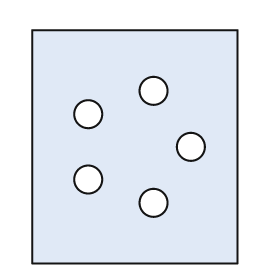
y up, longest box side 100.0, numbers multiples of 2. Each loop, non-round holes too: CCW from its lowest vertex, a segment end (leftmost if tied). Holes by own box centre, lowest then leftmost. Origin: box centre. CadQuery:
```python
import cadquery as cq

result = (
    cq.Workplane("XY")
    .moveTo(-44.0, -50.0)
    .lineTo(44.0, -50.0)
    .lineTo(44.0, 50.0)
    .lineTo(-44.0, 50.0)
    .close()
    .moveTo(8.0, -24.0)
    .circle(6.0)
    .moveTo(-20.0, -14.0)
    .circle(6.0)
    .moveTo(24.0, 0.0)
    .circle(6.0)
    .moveTo(-20.0, 14.0)
    .circle(6.0)
    .moveTo(8.0, 24.0)
    .circle(6.0)
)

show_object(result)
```